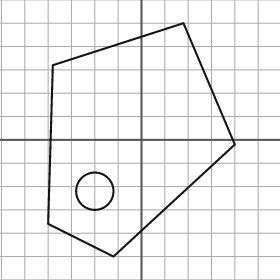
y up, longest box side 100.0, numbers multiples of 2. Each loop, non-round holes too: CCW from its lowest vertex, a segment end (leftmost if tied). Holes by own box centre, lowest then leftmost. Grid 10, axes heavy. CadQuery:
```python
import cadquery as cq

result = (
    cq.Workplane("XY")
    .moveTo(-12.0, -50.0)
    .lineTo(40.0, -2.0)
    .lineTo(18.0, 50.0)
    .lineTo(-38.0, 32.0)
    .lineTo(-40.0, -36.0)
    .close()
    .moveTo(-20.0, -22.0)
    .circle(8.0)
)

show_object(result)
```